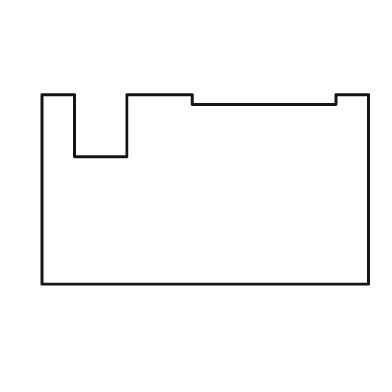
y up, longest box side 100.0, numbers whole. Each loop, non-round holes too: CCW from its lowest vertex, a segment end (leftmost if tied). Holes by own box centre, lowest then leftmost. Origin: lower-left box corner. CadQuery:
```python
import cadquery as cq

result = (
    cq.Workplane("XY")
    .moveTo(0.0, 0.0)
    .lineTo(100.0, 0.0)
    .lineTo(100.0, 58.0)
    .lineTo(90.0, 58.0)
    .lineTo(90.0, 55.0)
    .lineTo(46.0, 55.0)
    .lineTo(46.0, 58.0)
    .lineTo(26.0, 58.0)
    .lineTo(26.0, 39.0)
    .lineTo(10.0, 39.0)
    .lineTo(10.0, 58.0)
    .lineTo(0.0, 58.0)
    .close()
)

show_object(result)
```